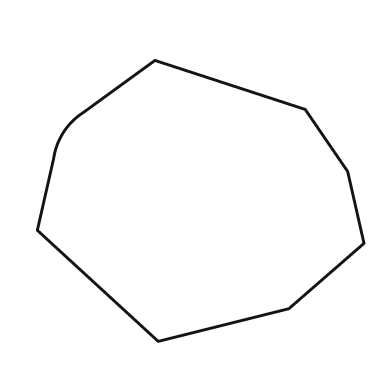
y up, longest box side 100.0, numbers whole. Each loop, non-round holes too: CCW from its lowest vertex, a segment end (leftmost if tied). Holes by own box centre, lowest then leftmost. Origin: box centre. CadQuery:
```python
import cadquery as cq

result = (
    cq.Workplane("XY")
    .moveTo(-13.0, -43.0)
    .lineTo(27.0, -33.0)
    .lineTo(50.0, -13.0)
    .lineTo(45.0, 9.0)
    .lineTo(32.0, 28.0)
    .lineTo(-14.0, 43.0)
    .lineTo(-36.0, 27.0)
    .threePointArc((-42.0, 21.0), (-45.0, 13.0))
    .lineTo(-50.0, -9.0)
    .close()
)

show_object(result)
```